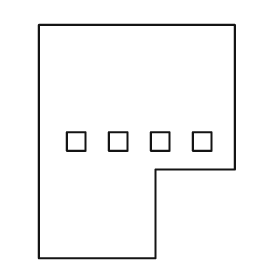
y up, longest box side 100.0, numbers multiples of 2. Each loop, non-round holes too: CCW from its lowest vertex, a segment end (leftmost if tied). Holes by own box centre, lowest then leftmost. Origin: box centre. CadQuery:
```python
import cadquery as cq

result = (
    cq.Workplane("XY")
    .moveTo(-42.0, -50.0)
    .lineTo(8.0, -50.0)
    .lineTo(8.0, -12.0)
    .lineTo(42.0, -12.0)
    .lineTo(42.0, 50.0)
    .lineTo(-42.0, 50.0)
    .close()
    .moveTo(-30.0, -4.0)
    .lineTo(-22.0, -4.0)
    .lineTo(-22.0, 4.0)
    .lineTo(-30.0, 4.0)
    .close()
    .moveTo(-12.0, -4.0)
    .lineTo(-4.0, -4.0)
    .lineTo(-4.0, 4.0)
    .lineTo(-12.0, 4.0)
    .close()
    .moveTo(6.0, -4.0)
    .lineTo(14.0, -4.0)
    .lineTo(14.0, 4.0)
    .lineTo(6.0, 4.0)
    .close()
    .moveTo(24.0, -4.0)
    .lineTo(32.0, -4.0)
    .lineTo(32.0, 4.0)
    .lineTo(24.0, 4.0)
    .close()
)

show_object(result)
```